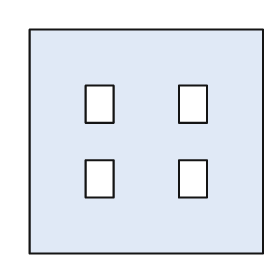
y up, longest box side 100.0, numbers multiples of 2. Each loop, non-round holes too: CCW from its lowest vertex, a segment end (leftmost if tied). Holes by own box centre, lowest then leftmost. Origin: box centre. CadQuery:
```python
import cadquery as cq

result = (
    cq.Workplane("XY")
    .moveTo(-50.0, -48.0)
    .lineTo(50.0, -48.0)
    .lineTo(50.0, 48.0)
    .lineTo(-50.0, 48.0)
    .close()
    .moveTo(-26.0, -24.0)
    .lineTo(-14.0, -24.0)
    .lineTo(-14.0, -8.0)
    .lineTo(-26.0, -8.0)
    .close()
    .moveTo(14.0, -24.0)
    .lineTo(26.0, -24.0)
    .lineTo(26.0, -8.0)
    .lineTo(14.0, -8.0)
    .close()
    .moveTo(-26.0, 8.0)
    .lineTo(-14.0, 8.0)
    .lineTo(-14.0, 24.0)
    .lineTo(-26.0, 24.0)
    .close()
    .moveTo(14.0, 8.0)
    .lineTo(26.0, 8.0)
    .lineTo(26.0, 24.0)
    .lineTo(14.0, 24.0)
    .close()
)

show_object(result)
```